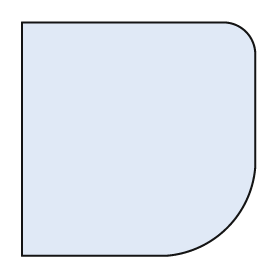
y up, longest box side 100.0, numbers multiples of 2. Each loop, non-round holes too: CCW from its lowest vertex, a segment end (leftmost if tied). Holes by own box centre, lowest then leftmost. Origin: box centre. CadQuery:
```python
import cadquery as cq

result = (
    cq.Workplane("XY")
    .moveTo(-50.0, -50.0)
    .lineTo(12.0, -50.0)
    .threePointArc((38.0, -38.0), (50.0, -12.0))
    .lineTo(50.0, 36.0)
    .threePointArc((46.0, 46.0), (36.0, 50.0))
    .lineTo(-50.0, 50.0)
    .close()
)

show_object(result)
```